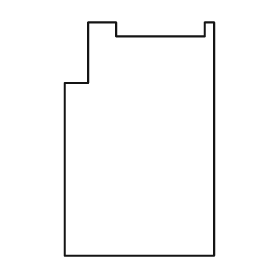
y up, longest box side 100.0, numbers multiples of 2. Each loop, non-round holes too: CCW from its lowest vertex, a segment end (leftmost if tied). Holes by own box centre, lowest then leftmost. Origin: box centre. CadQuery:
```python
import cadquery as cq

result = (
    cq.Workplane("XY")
    .moveTo(-32.0, -50.0)
    .lineTo(32.0, -50.0)
    .lineTo(32.0, 50.0)
    .lineTo(28.0, 50.0)
    .lineTo(28.0, 44.0)
    .lineTo(-10.0, 44.0)
    .lineTo(-10.0, 50.0)
    .lineTo(-22.0, 50.0)
    .lineTo(-22.0, 24.0)
    .lineTo(-32.0, 24.0)
    .close()
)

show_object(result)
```